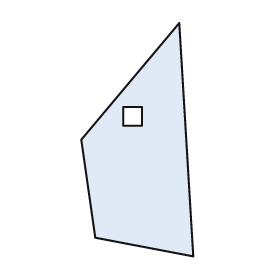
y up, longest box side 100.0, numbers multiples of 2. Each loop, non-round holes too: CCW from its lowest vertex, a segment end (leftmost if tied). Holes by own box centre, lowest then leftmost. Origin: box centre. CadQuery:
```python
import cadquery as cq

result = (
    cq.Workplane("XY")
    .moveTo(24.0, -50.0)
    .lineTo(18.0, 50.0)
    .lineTo(-24.0, 0.0)
    .lineTo(-18.0, -42.0)
    .close()
    .moveTo(-6.0, 6.0)
    .lineTo(2.0, 6.0)
    .lineTo(2.0, 14.0)
    .lineTo(-6.0, 14.0)
    .close()
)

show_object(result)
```